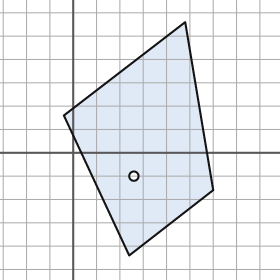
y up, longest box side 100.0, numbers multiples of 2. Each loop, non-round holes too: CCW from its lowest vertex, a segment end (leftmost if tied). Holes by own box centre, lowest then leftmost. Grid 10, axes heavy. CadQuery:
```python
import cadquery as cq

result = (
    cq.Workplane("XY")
    .moveTo(24.0, -44.0)
    .lineTo(60.0, -16.0)
    .lineTo(48.0, 56.0)
    .lineTo(-4.0, 16.0)
    .close()
    .moveTo(26.0, -10.0)
    .circle(2.0)
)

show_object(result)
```